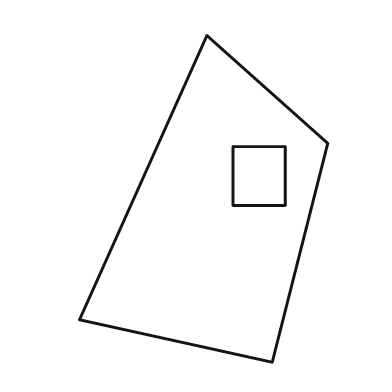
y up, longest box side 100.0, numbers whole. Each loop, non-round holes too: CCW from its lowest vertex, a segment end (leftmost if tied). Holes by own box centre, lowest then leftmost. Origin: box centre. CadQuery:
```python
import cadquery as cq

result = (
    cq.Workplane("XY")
    .moveTo(21.0, -50.0)
    .lineTo(38.0, 17.0)
    .lineTo(1.0, 50.0)
    .lineTo(-38.0, -37.0)
    .close()
    .moveTo(9.0, -2.0)
    .lineTo(25.0, -2.0)
    .lineTo(25.0, 16.0)
    .lineTo(9.0, 16.0)
    .close()
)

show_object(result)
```